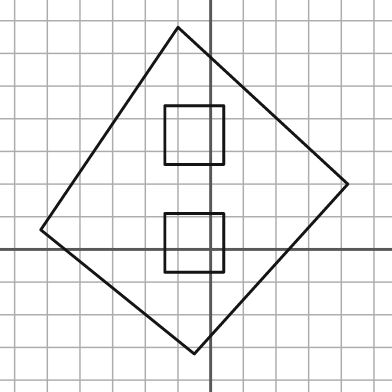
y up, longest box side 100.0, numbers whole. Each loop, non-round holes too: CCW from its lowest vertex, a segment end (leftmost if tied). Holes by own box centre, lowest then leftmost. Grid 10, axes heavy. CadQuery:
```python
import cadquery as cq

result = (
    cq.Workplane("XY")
    .moveTo(-5.0, -32.0)
    .lineTo(42.0, 20.0)
    .lineTo(-10.0, 68.0)
    .lineTo(-52.0, 6.0)
    .close()
    .moveTo(-14.0, -7.0)
    .lineTo(4.0, -7.0)
    .lineTo(4.0, 11.0)
    .lineTo(-14.0, 11.0)
    .close()
    .moveTo(-14.0, 26.0)
    .lineTo(4.0, 26.0)
    .lineTo(4.0, 44.0)
    .lineTo(-14.0, 44.0)
    .close()
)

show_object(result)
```